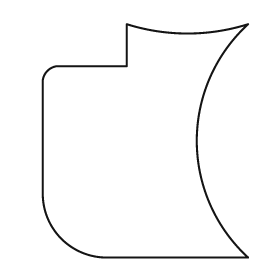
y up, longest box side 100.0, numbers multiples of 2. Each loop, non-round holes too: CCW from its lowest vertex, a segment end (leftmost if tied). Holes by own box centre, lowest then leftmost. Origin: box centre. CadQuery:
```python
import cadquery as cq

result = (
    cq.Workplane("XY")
    .moveTo(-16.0, -50.0)
    .lineTo(44.0, -50.0)
    .threePointArc((22.0, 0.0), (44.0, 50.0))
    .threePointArc((18.0, 46.0), (-8.0, 50.0))
    .lineTo(-8.0, 32.0)
    .lineTo(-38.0, 32.0)
    .threePointArc((-42.0, 30.0), (-44.0, 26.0))
    .lineTo(-44.0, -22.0)
    .threePointArc((-36.0, -42.0), (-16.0, -50.0))
    .close()
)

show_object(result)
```